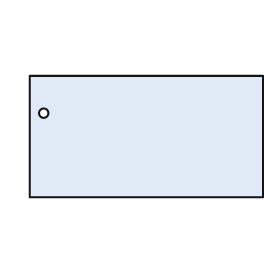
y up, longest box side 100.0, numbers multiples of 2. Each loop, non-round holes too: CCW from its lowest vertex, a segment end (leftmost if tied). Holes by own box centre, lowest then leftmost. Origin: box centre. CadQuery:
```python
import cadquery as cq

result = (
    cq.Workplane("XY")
    .moveTo(-50.0, -26.0)
    .lineTo(50.0, -26.0)
    .lineTo(50.0, 26.0)
    .lineTo(-50.0, 26.0)
    .close()
    .moveTo(-44.0, 10.0)
    .circle(2.0)
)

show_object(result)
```